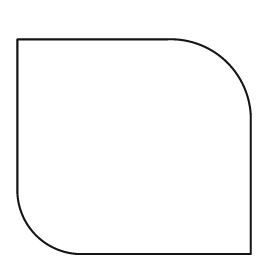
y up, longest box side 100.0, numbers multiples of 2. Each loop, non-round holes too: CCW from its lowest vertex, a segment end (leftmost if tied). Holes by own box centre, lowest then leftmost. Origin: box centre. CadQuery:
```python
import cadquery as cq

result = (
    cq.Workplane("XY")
    .moveTo(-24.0, -46.0)
    .lineTo(50.0, -46.0)
    .lineTo(50.0, 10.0)
    .threePointArc((40.0, 36.0), (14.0, 46.0))
    .lineTo(-50.0, 46.0)
    .lineTo(-50.0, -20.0)
    .threePointArc((-42.0, -38.0), (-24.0, -46.0))
    .close()
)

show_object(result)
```